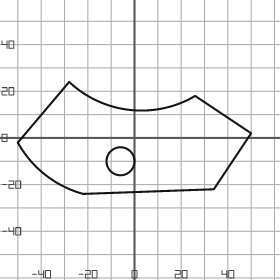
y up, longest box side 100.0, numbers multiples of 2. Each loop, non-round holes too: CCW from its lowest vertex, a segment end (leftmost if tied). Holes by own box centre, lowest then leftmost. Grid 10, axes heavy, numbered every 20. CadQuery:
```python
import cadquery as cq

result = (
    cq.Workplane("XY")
    .moveTo(-22.0, -24.0)
    .lineTo(34.0, -22.0)
    .lineTo(50.0, 2.0)
    .lineTo(26.0, 18.0)
    .threePointArc((-2.0, 12.0), (-28.0, 24.0))
    .lineTo(-50.0, -2.0)
    .threePointArc((-38.0, -16.0), (-22.0, -24.0))
    .close()
    .moveTo(-6.0, -10.0)
    .circle(6.0)
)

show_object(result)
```